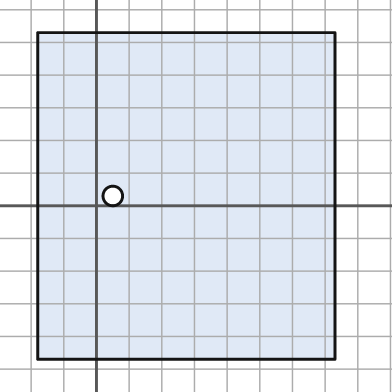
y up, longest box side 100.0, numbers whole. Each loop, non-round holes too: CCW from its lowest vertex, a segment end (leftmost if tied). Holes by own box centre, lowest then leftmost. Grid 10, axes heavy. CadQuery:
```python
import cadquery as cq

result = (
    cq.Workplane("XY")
    .moveTo(-18.0, -47.0)
    .lineTo(73.0, -47.0)
    .lineTo(73.0, 53.0)
    .lineTo(-18.0, 53.0)
    .close()
    .moveTo(5.0, 3.0)
    .circle(3.0)
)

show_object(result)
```